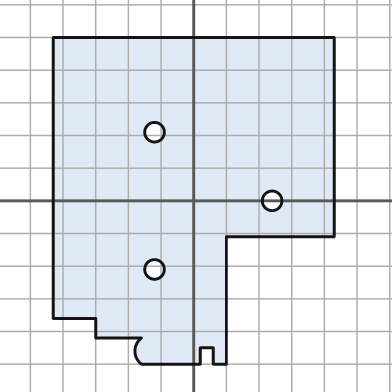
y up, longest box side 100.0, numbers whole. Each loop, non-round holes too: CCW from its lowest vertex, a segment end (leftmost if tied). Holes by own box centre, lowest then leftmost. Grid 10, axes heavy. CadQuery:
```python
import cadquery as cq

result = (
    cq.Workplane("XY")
    .moveTo(-16.0, -50.0)
    .lineTo(2.0, -50.0)
    .lineTo(2.0, -45.0)
    .lineTo(6.0, -45.0)
    .lineTo(6.0, -50.0)
    .lineTo(10.0, -50.0)
    .lineTo(10.0, -11.0)
    .lineTo(43.0, -11.0)
    .lineTo(43.0, 50.0)
    .lineTo(-43.0, 50.0)
    .lineTo(-43.0, -36.0)
    .lineTo(-30.0, -36.0)
    .lineTo(-30.0, -42.0)
    .lineTo(-16.0, -42.0)
    .threePointArc((-18.0, -46.0), (-16.0, -50.0))
    .close()
    .moveTo(-12.0, -21.0)
    .circle(3.0)
    .moveTo(24.0, 0.0)
    .circle(3.0)
    .moveTo(-12.0, 21.0)
    .circle(3.0)
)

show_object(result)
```